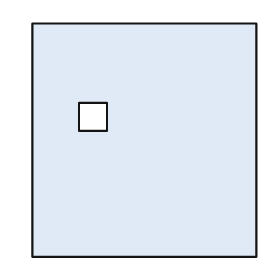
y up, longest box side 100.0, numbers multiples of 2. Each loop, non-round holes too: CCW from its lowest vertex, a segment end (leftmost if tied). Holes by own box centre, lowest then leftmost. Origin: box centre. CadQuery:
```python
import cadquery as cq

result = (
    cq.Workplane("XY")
    .moveTo(-48.0, -50.0)
    .lineTo(48.0, -50.0)
    .lineTo(48.0, 50.0)
    .lineTo(-48.0, 50.0)
    .close()
    .moveTo(-28.0, 4.0)
    .lineTo(-16.0, 4.0)
    .lineTo(-16.0, 16.0)
    .lineTo(-28.0, 16.0)
    .close()
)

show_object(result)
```